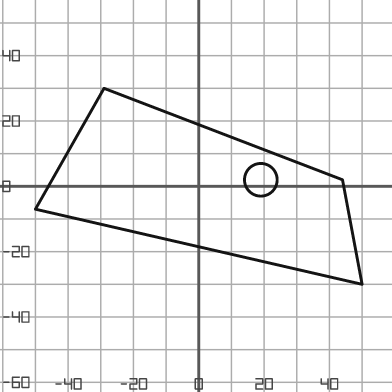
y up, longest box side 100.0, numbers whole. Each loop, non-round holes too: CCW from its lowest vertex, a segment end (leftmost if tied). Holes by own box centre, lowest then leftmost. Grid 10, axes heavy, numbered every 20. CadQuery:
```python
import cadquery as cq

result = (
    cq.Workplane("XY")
    .moveTo(50.0, -30.0)
    .lineTo(44.0, 2.0)
    .lineTo(-29.0, 30.0)
    .lineTo(-50.0, -7.0)
    .close()
    .moveTo(19.0, 2.0)
    .circle(5.0)
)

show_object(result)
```